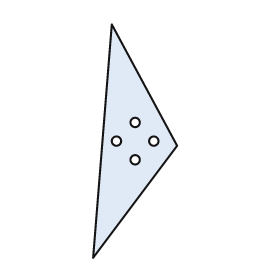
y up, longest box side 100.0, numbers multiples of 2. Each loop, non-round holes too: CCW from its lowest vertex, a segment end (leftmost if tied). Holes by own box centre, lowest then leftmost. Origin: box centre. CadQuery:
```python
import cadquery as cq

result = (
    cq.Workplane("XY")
    .moveTo(-18.0, -50.0)
    .lineTo(18.0, -2.0)
    .lineTo(-10.0, 50.0)
    .close()
    .moveTo(0.0, -8.0)
    .circle(2.0)
    .moveTo(-8.0, 0.0)
    .circle(2.0)
    .moveTo(8.0, 0.0)
    .circle(2.0)
    .moveTo(0.0, 8.0)
    .circle(2.0)
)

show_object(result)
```